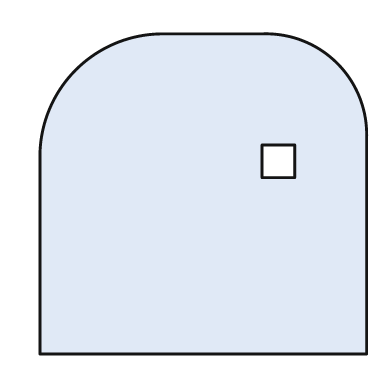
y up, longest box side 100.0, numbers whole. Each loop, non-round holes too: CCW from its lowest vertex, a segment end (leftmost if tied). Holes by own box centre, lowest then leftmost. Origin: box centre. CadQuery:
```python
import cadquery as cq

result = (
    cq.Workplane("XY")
    .moveTo(-50.0, -49.0)
    .lineTo(50.0, -49.0)
    .lineTo(50.0, 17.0)
    .threePointArc((41.0, 40.0), (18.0, 49.0))
    .lineTo(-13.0, 49.0)
    .threePointArc((-39.0, 38.0), (-50.0, 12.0))
    .close()
    .moveTo(18.0, 5.0)
    .lineTo(28.0, 5.0)
    .lineTo(28.0, 15.0)
    .lineTo(18.0, 15.0)
    .close()
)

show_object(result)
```